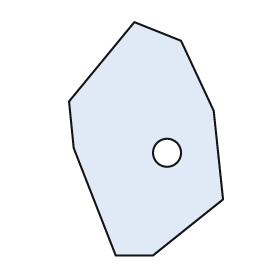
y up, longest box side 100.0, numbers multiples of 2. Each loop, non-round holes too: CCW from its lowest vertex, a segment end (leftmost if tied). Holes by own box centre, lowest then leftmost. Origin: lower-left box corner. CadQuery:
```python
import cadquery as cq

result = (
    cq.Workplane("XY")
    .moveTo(20.0, 0.0)
    .lineTo(36.0, 0.0)
    .lineTo(66.0, 24.0)
    .lineTo(62.0, 62.0)
    .lineTo(48.0, 92.0)
    .lineTo(28.0, 100.0)
    .lineTo(0.0, 66.0)
    .lineTo(2.0, 46.0)
    .close()
    .moveTo(42.0, 44.0)
    .circle(6.0)
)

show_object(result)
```